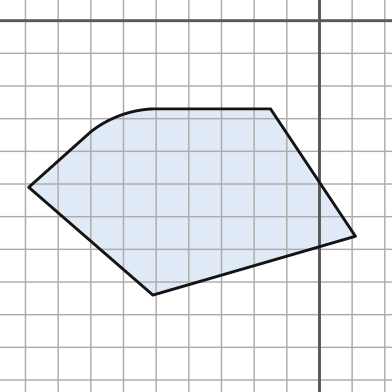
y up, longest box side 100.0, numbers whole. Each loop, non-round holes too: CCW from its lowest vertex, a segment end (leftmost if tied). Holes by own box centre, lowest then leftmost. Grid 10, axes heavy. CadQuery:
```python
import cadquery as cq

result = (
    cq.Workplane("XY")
    .moveTo(-51.0, -84.0)
    .lineTo(11.0, -66.0)
    .lineTo(-15.0, -27.0)
    .lineTo(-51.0, -27.0)
    .threePointArc((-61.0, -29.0), (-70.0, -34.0))
    .lineTo(-89.0, -51.0)
    .close()
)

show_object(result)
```